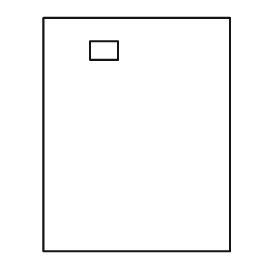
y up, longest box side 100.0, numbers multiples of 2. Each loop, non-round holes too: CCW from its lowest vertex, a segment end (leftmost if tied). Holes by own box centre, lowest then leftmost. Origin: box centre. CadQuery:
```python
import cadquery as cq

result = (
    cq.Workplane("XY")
    .moveTo(-40.0, -50.0)
    .lineTo(40.0, -50.0)
    .lineTo(40.0, 50.0)
    .lineTo(-40.0, 50.0)
    .close()
    .moveTo(-20.0, 32.0)
    .lineTo(-8.0, 32.0)
    .lineTo(-8.0, 40.0)
    .lineTo(-20.0, 40.0)
    .close()
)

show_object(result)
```